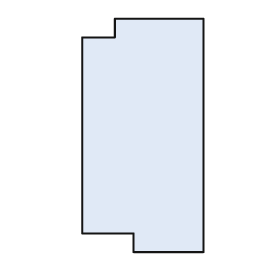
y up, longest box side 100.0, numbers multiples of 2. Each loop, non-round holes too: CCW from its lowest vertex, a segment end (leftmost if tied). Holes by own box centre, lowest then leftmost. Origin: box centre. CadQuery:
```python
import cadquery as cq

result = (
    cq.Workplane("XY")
    .moveTo(-4.0, -50.0)
    .lineTo(26.0, -50.0)
    .lineTo(26.0, 50.0)
    .lineTo(-12.0, 50.0)
    .lineTo(-12.0, 42.0)
    .lineTo(-26.0, 42.0)
    .lineTo(-26.0, -42.0)
    .lineTo(-4.0, -42.0)
    .close()
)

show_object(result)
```